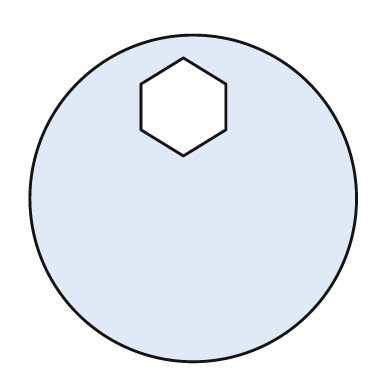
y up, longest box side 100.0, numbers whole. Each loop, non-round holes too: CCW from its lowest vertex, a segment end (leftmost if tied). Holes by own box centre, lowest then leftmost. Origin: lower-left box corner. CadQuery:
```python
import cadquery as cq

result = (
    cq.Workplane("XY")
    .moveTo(50.0, 50.0)
    .circle(50.0)
    .moveTo(47.0, 63.0)
    .lineTo(60.0, 71.0)
    .lineTo(60.0, 85.0)
    .lineTo(47.0, 93.0)
    .lineTo(34.0, 85.0)
    .lineTo(34.0, 71.0)
    .close()
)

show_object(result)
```